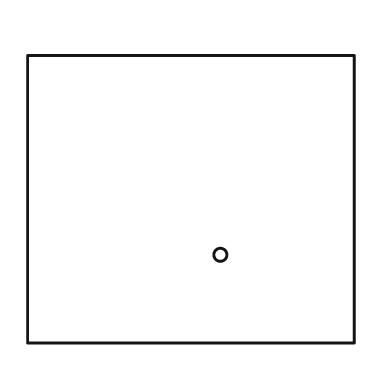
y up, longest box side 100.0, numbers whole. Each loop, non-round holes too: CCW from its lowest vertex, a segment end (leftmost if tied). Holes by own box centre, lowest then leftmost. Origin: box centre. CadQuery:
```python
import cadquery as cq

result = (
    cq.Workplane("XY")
    .moveTo(-50.0, -44.0)
    .lineTo(50.0, -44.0)
    .lineTo(50.0, 44.0)
    .lineTo(-50.0, 44.0)
    .close()
    .moveTo(9.0, -17.0)
    .circle(2.0)
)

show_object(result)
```